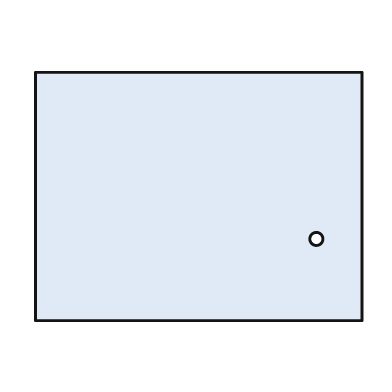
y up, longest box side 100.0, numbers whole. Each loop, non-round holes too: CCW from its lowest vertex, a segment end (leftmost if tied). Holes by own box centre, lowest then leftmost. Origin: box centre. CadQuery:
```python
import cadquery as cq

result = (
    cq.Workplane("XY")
    .moveTo(-50.0, -38.0)
    .lineTo(50.0, -38.0)
    .lineTo(50.0, 38.0)
    .lineTo(-50.0, 38.0)
    .close()
    .moveTo(36.0, -13.0)
    .circle(2.0)
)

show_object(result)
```